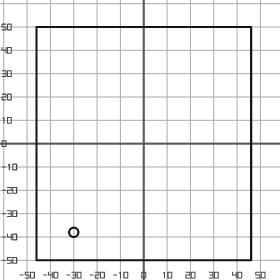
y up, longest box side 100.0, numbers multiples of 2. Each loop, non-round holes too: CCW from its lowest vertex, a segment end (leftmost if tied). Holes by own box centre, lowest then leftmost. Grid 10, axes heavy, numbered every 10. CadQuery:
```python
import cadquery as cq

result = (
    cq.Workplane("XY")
    .moveTo(-46.0, -50.0)
    .lineTo(46.0, -50.0)
    .lineTo(46.0, 50.0)
    .lineTo(-46.0, 50.0)
    .close()
    .moveTo(-30.0, -38.0)
    .circle(2.0)
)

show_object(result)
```